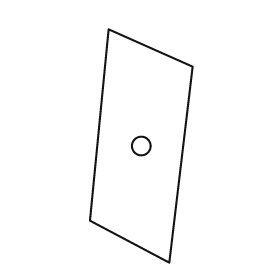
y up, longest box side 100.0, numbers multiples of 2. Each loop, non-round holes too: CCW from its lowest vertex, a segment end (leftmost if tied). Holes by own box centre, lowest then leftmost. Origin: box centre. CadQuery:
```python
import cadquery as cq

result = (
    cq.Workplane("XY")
    .moveTo(12.0, -50.0)
    .lineTo(22.0, 34.0)
    .lineTo(-14.0, 50.0)
    .lineTo(-22.0, -32.0)
    .close()
    .moveTo(0.0, 0.0)
    .circle(4.0)
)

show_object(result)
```